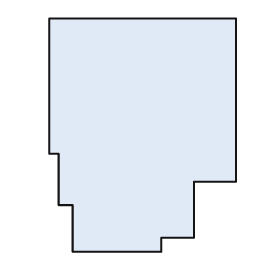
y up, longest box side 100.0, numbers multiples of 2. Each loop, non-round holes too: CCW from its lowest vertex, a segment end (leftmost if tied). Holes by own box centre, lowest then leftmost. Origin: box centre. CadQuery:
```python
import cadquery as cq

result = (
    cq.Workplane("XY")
    .moveTo(-30.0, -50.0)
    .lineTo(8.0, -50.0)
    .lineTo(8.0, -44.0)
    .lineTo(22.0, -44.0)
    .lineTo(22.0, -20.0)
    .lineTo(40.0, -20.0)
    .lineTo(40.0, 50.0)
    .lineTo(-40.0, 50.0)
    .lineTo(-40.0, -8.0)
    .lineTo(-36.0, -8.0)
    .lineTo(-36.0, -30.0)
    .lineTo(-30.0, -30.0)
    .close()
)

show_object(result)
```